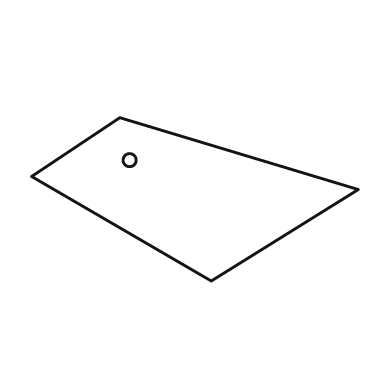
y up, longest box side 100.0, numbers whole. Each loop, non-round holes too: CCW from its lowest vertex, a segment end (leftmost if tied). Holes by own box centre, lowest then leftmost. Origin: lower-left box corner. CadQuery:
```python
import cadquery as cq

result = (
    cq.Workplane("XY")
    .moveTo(55.0, 0.0)
    .lineTo(100.0, 28.0)
    .lineTo(27.0, 50.0)
    .lineTo(0.0, 32.0)
    .close()
    .moveTo(30.0, 37.0)
    .circle(2.0)
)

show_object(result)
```